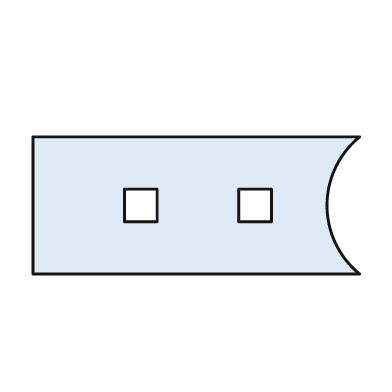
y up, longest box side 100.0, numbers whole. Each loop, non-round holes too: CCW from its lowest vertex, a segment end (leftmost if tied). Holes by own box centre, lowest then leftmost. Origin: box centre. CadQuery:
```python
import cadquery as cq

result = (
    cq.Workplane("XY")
    .moveTo(-50.0, -21.0)
    .lineTo(50.0, -21.0)
    .threePointArc((40.0, 0.0), (50.0, 21.0))
    .lineTo(-50.0, 21.0)
    .close()
    .moveTo(-22.0, -5.0)
    .lineTo(-12.0, -5.0)
    .lineTo(-12.0, 5.0)
    .lineTo(-22.0, 5.0)
    .close()
    .moveTo(13.0, -5.0)
    .lineTo(23.0, -5.0)
    .lineTo(23.0, 5.0)
    .lineTo(13.0, 5.0)
    .close()
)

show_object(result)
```